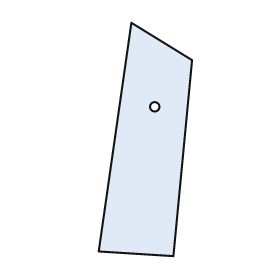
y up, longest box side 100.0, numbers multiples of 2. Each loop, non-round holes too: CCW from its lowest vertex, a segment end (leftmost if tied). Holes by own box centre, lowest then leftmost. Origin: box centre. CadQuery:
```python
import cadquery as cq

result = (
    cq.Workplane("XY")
    .moveTo(12.0, -50.0)
    .lineTo(20.0, 34.0)
    .lineTo(-6.0, 50.0)
    .lineTo(-20.0, -48.0)
    .close()
    .moveTo(4.0, 14.0)
    .circle(2.0)
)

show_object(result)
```